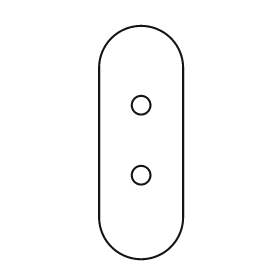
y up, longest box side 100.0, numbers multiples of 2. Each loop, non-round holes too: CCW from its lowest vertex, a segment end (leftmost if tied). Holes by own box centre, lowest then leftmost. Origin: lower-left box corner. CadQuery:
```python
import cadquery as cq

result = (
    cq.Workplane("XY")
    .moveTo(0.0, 18.0)
    .threePointArc((18.0, 0.0), (36.0, 18.0))
    .lineTo(36.0, 82.0)
    .threePointArc((18.0, 100.0), (0.0, 82.0))
    .close()
    .moveTo(18.0, 36.0)
    .circle(4.0)
    .moveTo(18.0, 66.0)
    .circle(4.0)
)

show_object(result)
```